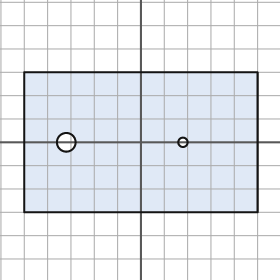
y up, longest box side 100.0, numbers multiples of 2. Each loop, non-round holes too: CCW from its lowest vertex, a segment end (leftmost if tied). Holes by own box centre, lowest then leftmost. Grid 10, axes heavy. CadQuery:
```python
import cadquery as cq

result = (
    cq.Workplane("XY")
    .moveTo(-50.0, -30.0)
    .lineTo(50.0, -30.0)
    .lineTo(50.0, 30.0)
    .lineTo(-50.0, 30.0)
    .close()
    .moveTo(-32.0, 0.0)
    .circle(4.0)
    .moveTo(18.0, 0.0)
    .circle(2.0)
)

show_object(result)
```